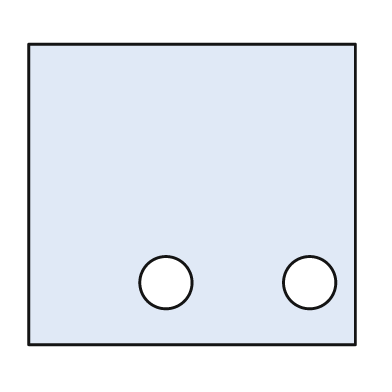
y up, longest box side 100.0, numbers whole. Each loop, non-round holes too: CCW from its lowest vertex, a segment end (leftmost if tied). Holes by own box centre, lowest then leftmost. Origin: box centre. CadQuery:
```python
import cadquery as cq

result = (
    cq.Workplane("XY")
    .moveTo(-50.0, -46.0)
    .lineTo(50.0, -46.0)
    .lineTo(50.0, 46.0)
    .lineTo(-50.0, 46.0)
    .close()
    .moveTo(-8.0, -27.0)
    .circle(8.0)
    .moveTo(36.0, -27.0)
    .circle(8.0)
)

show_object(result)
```